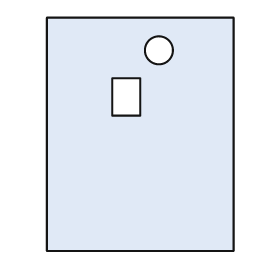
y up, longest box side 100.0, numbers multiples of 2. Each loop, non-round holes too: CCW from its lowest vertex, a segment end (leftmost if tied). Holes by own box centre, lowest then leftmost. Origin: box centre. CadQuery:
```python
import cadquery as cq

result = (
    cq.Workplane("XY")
    .moveTo(-40.0, -50.0)
    .lineTo(40.0, -50.0)
    .lineTo(40.0, 50.0)
    .lineTo(-40.0, 50.0)
    .close()
    .moveTo(-12.0, 8.0)
    .lineTo(0.0, 8.0)
    .lineTo(0.0, 24.0)
    .lineTo(-12.0, 24.0)
    .close()
    .moveTo(8.0, 36.0)
    .circle(6.0)
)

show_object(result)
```